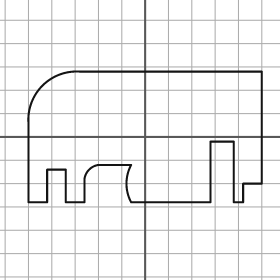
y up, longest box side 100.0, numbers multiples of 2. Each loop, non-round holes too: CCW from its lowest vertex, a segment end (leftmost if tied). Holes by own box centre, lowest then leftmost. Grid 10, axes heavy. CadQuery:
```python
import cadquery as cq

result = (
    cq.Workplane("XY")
    .moveTo(-50.0, -28.0)
    .lineTo(-42.0, -28.0)
    .lineTo(-42.0, -14.0)
    .lineTo(-34.0, -14.0)
    .lineTo(-34.0, -28.0)
    .lineTo(-26.0, -28.0)
    .lineTo(-26.0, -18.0)
    .threePointArc((-24.0, -14.0), (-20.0, -12.0))
    .lineTo(-6.0, -12.0)
    .threePointArc((-8.0, -20.0), (-6.0, -28.0))
    .lineTo(28.0, -28.0)
    .lineTo(28.0, -2.0)
    .lineTo(38.0, -2.0)
    .lineTo(38.0, -28.0)
    .lineTo(42.0, -28.0)
    .lineTo(42.0, -20.0)
    .lineTo(50.0, -20.0)
    .lineTo(50.0, 28.0)
    .lineTo(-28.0, 28.0)
    .threePointArc((-44.0, 22.0), (-50.0, 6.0))
    .close()
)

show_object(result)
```